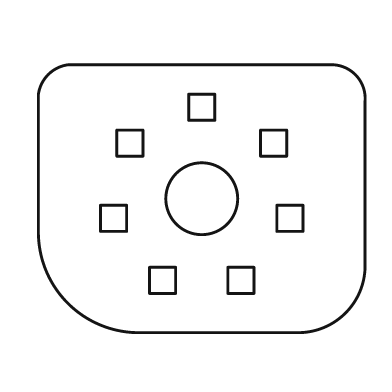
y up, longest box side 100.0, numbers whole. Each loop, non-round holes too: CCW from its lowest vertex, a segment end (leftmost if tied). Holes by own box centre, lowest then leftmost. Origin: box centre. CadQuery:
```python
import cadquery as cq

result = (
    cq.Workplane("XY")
    .moveTo(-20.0, -41.0)
    .lineTo(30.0, -41.0)
    .threePointArc((44.0, -35.0), (50.0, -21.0))
    .lineTo(50.0, 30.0)
    .threePointArc((47.0, 38.0), (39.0, 41.0))
    .lineTo(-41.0, 41.0)
    .threePointArc((-47.0, 38.0), (-50.0, 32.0))
    .lineTo(-50.0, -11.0)
    .threePointArc((-41.0, -32.0), (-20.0, -41.0))
    .close()
    .moveTo(-16.0, -29.0)
    .lineTo(-8.0, -29.0)
    .lineTo(-8.0, -21.0)
    .lineTo(-16.0, -21.0)
    .close()
    .moveTo(8.0, -29.0)
    .lineTo(16.0, -29.0)
    .lineTo(16.0, -21.0)
    .lineTo(8.0, -21.0)
    .close()
    .moveTo(-31.0, -10.0)
    .lineTo(-23.0, -10.0)
    .lineTo(-23.0, -2.0)
    .lineTo(-31.0, -2.0)
    .close()
    .moveTo(23.0, -10.0)
    .lineTo(31.0, -10.0)
    .lineTo(31.0, -2.0)
    .lineTo(23.0, -2.0)
    .close()
    .moveTo(0.0, 0.0)
    .circle(11.0)
    .moveTo(-26.0, 13.0)
    .lineTo(-18.0, 13.0)
    .lineTo(-18.0, 21.0)
    .lineTo(-26.0, 21.0)
    .close()
    .moveTo(18.0, 13.0)
    .lineTo(26.0, 13.0)
    .lineTo(26.0, 21.0)
    .lineTo(18.0, 21.0)
    .close()
    .moveTo(-4.0, 24.0)
    .lineTo(4.0, 24.0)
    .lineTo(4.0, 32.0)
    .lineTo(-4.0, 32.0)
    .close()
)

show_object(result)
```